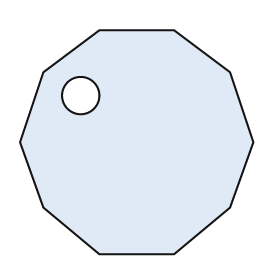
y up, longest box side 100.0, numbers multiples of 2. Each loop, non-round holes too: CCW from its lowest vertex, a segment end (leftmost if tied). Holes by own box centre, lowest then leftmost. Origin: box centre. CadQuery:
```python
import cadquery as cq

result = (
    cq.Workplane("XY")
    .moveTo(-16.0, -48.0)
    .lineTo(16.0, -48.0)
    .lineTo(40.0, -28.0)
    .lineTo(50.0, 0.0)
    .lineTo(40.0, 30.0)
    .lineTo(16.0, 48.0)
    .lineTo(-16.0, 48.0)
    .lineTo(-40.0, 30.0)
    .lineTo(-50.0, 0.0)
    .lineTo(-40.0, -28.0)
    .close()
    .moveTo(-24.0, 20.0)
    .circle(8.0)
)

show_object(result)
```